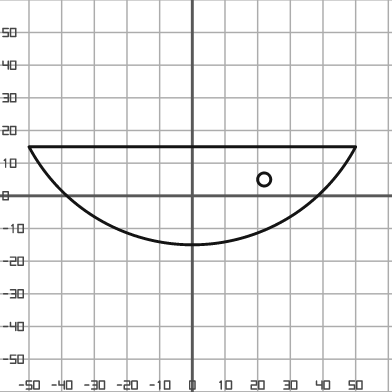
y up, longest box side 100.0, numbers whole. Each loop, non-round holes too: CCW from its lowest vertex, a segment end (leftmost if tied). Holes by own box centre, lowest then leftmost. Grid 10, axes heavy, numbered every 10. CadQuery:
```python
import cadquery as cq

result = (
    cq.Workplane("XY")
    .moveTo(-50.0, 15.0)
    .threePointArc((0.0, -15.0), (50.0, 15.0))
    .close()
    .moveTo(22.0, 5.0)
    .circle(2.0)
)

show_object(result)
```